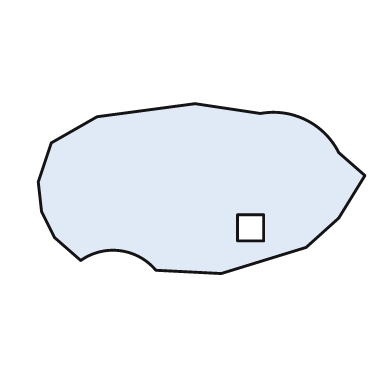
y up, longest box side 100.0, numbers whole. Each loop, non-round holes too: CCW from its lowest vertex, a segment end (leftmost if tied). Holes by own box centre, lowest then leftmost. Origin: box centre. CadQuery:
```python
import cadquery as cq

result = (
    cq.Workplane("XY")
    .moveTo(6.0, -26.0)
    .lineTo(32.0, -18.0)
    .lineTo(42.0, -9.0)
    .lineTo(50.0, 4.0)
    .lineTo(42.0, 11.0)
    .threePointArc((32.0, 21.0), (18.0, 23.0))
    .lineTo(-2.0, 26.0)
    .lineTo(-32.0, 22.0)
    .lineTo(-46.0, 14.0)
    .lineTo(-50.0, 2.0)
    .lineTo(-49.0, -7.0)
    .lineTo(-45.0, -15.0)
    .lineTo(-37.0, -22.0)
    .threePointArc((-25.0, -19.0), (-14.0, -25.0))
    .close()
    .moveTo(11.0, -16.0)
    .lineTo(19.0, -16.0)
    .lineTo(19.0, -8.0)
    .lineTo(11.0, -8.0)
    .close()
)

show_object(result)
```